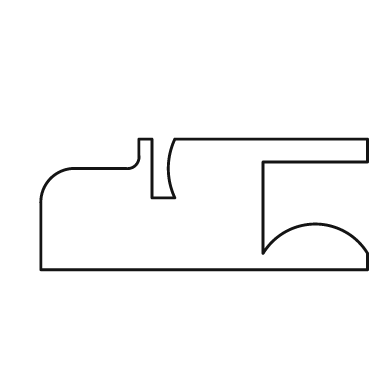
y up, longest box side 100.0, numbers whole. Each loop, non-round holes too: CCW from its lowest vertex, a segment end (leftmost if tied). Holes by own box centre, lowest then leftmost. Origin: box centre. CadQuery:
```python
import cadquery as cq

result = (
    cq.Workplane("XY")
    .moveTo(-50.0, -20.0)
    .lineTo(50.0, -20.0)
    .lineTo(50.0, -15.0)
    .threePointArc((34.0, -6.0), (18.0, -15.0))
    .lineTo(18.0, 13.0)
    .lineTo(50.0, 13.0)
    .lineTo(50.0, 20.0)
    .lineTo(-9.0, 20.0)
    .threePointArc((-11.0, 11.0), (-9.0, 2.0))
    .lineTo(-16.0, 2.0)
    .lineTo(-16.0, 20.0)
    .lineTo(-20.0, 20.0)
    .lineTo(-20.0, 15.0)
    .threePointArc((-21.0, 12.0), (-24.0, 11.0))
    .lineTo(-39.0, 11.0)
    .threePointArc((-47.0, 8.0), (-50.0, 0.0))
    .close()
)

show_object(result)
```